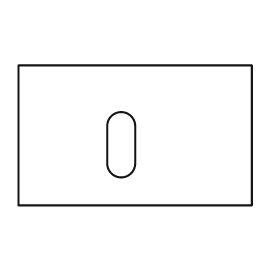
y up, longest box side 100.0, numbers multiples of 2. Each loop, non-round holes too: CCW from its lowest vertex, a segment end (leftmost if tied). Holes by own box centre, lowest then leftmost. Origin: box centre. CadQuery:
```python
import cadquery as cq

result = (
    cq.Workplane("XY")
    .moveTo(-50.0, -30.0)
    .lineTo(50.0, -30.0)
    .lineTo(50.0, 30.0)
    .lineTo(-50.0, 30.0)
    .close()
    .moveTo(-12.0, -12.0)
    .threePointArc((-6.0, -18.0), (0.0, -12.0))
    .lineTo(0.0, 4.0)
    .threePointArc((-6.0, 10.0), (-12.0, 4.0))
    .close()
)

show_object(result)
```